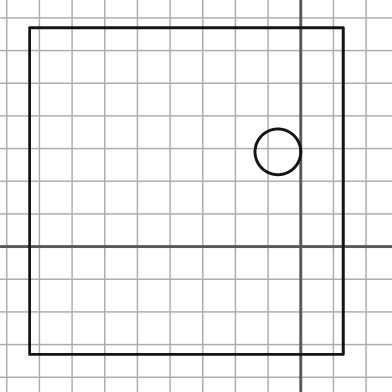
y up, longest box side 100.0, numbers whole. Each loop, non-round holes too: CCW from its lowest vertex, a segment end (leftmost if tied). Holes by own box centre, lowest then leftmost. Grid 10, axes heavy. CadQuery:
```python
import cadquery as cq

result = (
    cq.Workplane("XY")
    .moveTo(-83.0, -33.0)
    .lineTo(13.0, -33.0)
    .lineTo(13.0, 67.0)
    .lineTo(-83.0, 67.0)
    .close()
    .moveTo(-7.0, 29.0)
    .circle(7.0)
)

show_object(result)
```